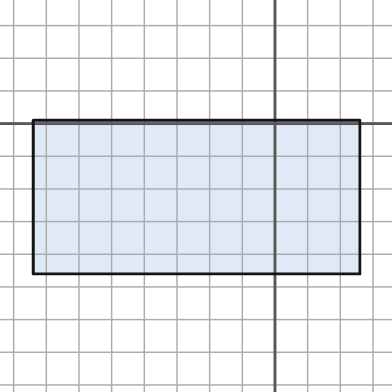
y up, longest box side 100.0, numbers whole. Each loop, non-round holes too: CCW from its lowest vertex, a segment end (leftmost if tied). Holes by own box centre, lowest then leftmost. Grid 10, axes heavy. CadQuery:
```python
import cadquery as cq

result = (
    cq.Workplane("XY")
    .moveTo(-74.0, -46.0)
    .lineTo(26.0, -46.0)
    .lineTo(26.0, 1.0)
    .lineTo(-74.0, 1.0)
    .close()
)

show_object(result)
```